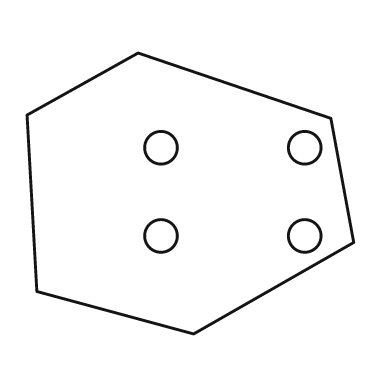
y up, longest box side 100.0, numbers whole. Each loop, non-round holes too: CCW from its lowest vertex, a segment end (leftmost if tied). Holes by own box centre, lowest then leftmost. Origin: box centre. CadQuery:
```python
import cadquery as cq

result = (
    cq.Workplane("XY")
    .moveTo(1.0, -43.0)
    .lineTo(50.0, -15.0)
    .lineTo(43.0, 23.0)
    .lineTo(-16.0, 43.0)
    .lineTo(-50.0, 24.0)
    .lineTo(-47.0, -30.0)
    .close()
    .moveTo(-9.0, -13.0)
    .circle(5.0)
    .moveTo(35.0, -13.0)
    .circle(5.0)
    .moveTo(-9.0, 14.0)
    .circle(5.0)
    .moveTo(35.0, 14.0)
    .circle(5.0)
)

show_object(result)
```